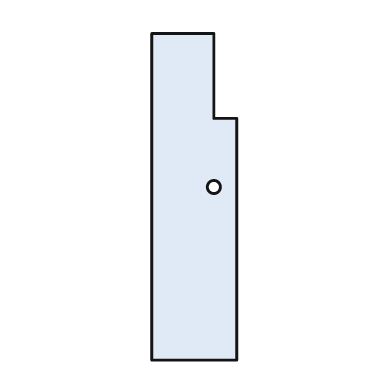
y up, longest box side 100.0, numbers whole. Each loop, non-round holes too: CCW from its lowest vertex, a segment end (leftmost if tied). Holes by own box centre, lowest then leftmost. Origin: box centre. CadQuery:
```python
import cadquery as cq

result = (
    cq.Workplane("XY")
    .moveTo(-13.0, -50.0)
    .lineTo(13.0, -50.0)
    .lineTo(13.0, 24.0)
    .lineTo(6.0, 24.0)
    .lineTo(6.0, 50.0)
    .lineTo(-13.0, 50.0)
    .close()
    .moveTo(6.0, 3.0)
    .circle(2.0)
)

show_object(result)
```